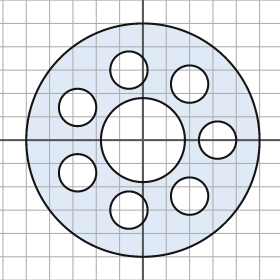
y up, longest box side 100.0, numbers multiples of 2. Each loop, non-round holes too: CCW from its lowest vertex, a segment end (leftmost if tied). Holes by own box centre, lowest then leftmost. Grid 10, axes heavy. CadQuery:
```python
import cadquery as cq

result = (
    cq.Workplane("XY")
    .moveTo(0.0, 0.0)
    .circle(50.0)
    .moveTo(-6.0, -30.0)
    .circle(8.0)
    .moveTo(20.0, -24.0)
    .circle(8.0)
    .moveTo(-28.0, -14.0)
    .circle(8.0)
    .moveTo(0.0, 0.0)
    .circle(18.0)
    .moveTo(32.0, 0.0)
    .circle(8.0)
    .moveTo(-28.0, 14.0)
    .circle(8.0)
    .moveTo(20.0, 24.0)
    .circle(8.0)
    .moveTo(-6.0, 30.0)
    .circle(8.0)
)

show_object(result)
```